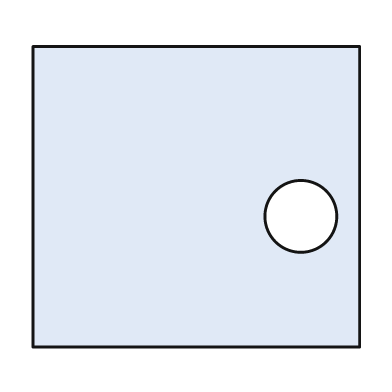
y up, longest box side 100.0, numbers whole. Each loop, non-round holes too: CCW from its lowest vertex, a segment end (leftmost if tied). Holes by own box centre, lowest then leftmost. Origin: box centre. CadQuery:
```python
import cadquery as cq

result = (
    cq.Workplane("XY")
    .moveTo(-50.0, -46.0)
    .lineTo(50.0, -46.0)
    .lineTo(50.0, 46.0)
    .lineTo(-50.0, 46.0)
    .close()
    .moveTo(32.0, -6.0)
    .circle(11.0)
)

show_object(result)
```